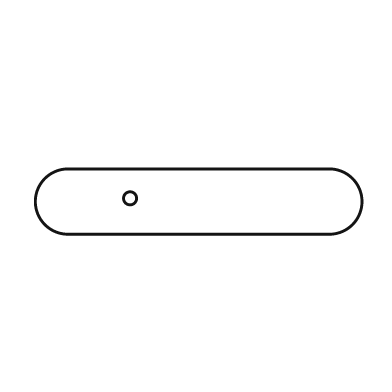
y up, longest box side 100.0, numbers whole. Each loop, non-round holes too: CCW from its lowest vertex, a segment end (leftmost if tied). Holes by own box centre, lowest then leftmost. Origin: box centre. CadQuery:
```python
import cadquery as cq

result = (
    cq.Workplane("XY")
    .moveTo(-40.0, -10.0)
    .lineTo(40.0, -10.0)
    .threePointArc((50.0, 0.0), (40.0, 10.0))
    .lineTo(-40.0, 10.0)
    .threePointArc((-50.0, 0.0), (-40.0, -10.0))
    .close()
    .moveTo(-21.0, 1.0)
    .circle(2.0)
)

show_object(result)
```